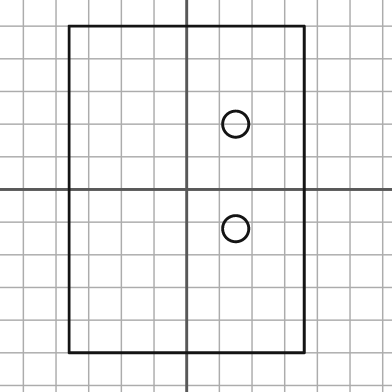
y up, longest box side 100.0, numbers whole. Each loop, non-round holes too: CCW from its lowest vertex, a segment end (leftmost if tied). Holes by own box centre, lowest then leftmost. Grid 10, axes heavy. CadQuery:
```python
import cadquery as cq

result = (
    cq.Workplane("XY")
    .moveTo(-36.0, -50.0)
    .lineTo(36.0, -50.0)
    .lineTo(36.0, 50.0)
    .lineTo(-36.0, 50.0)
    .close()
    .moveTo(15.0, -12.0)
    .circle(4.0)
    .moveTo(15.0, 20.0)
    .circle(4.0)
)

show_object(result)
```